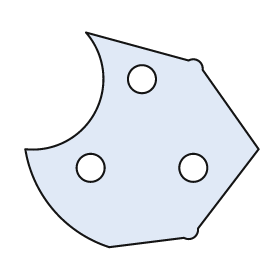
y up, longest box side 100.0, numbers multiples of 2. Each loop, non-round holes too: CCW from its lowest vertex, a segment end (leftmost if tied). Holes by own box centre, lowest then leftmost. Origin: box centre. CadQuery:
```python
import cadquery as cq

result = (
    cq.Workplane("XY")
    .moveTo(-14.0, -46.0)
    .lineTo(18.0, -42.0)
    .threePointArc((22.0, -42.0), (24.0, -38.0))
    .lineTo(50.0, -4.0)
    .lineTo(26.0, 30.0)
    .threePointArc((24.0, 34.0), (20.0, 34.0))
    .lineTo(-24.0, 46.0)
    .threePointArc((-20.0, 12.0), (-50.0, -4.0))
    .threePointArc((-38.0, -30.0), (-14.0, -46.0))
    .close()
    .moveTo(-22.0, -12.0)
    .circle(6.0)
    .moveTo(22.0, -12.0)
    .circle(6.0)
    .moveTo(0.0, 26.0)
    .circle(6.0)
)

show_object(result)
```